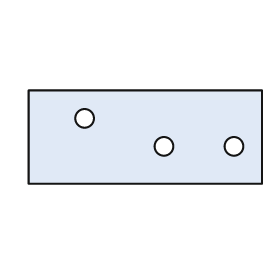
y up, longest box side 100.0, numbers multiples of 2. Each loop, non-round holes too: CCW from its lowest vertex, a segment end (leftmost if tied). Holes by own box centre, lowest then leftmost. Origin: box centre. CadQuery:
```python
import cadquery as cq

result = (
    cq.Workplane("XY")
    .moveTo(-50.0, -20.0)
    .lineTo(50.0, -20.0)
    .lineTo(50.0, 20.0)
    .lineTo(-50.0, 20.0)
    .close()
    .moveTo(8.0, -4.0)
    .circle(4.0)
    .moveTo(38.0, -4.0)
    .circle(4.0)
    .moveTo(-26.0, 8.0)
    .circle(4.0)
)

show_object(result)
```